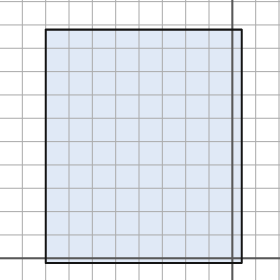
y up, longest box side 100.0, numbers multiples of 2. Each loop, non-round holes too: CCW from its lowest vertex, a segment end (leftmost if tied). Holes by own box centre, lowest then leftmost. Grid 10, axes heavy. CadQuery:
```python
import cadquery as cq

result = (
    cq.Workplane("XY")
    .moveTo(-80.0, -2.0)
    .lineTo(4.0, -2.0)
    .lineTo(4.0, 98.0)
    .lineTo(-80.0, 98.0)
    .close()
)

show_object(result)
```